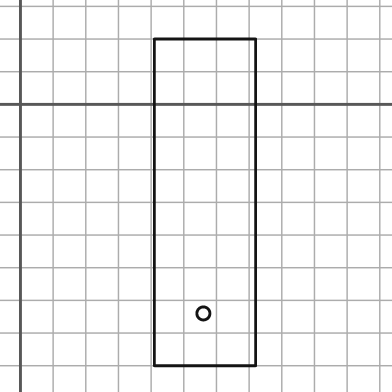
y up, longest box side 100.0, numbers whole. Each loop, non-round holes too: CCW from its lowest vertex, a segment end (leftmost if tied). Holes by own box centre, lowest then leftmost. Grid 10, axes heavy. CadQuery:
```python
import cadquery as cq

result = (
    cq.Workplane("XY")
    .moveTo(41.0, -80.0)
    .lineTo(72.0, -80.0)
    .lineTo(72.0, 20.0)
    .lineTo(41.0, 20.0)
    .close()
    .moveTo(56.0, -64.0)
    .circle(2.0)
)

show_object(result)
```